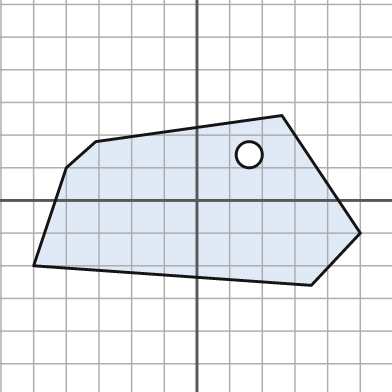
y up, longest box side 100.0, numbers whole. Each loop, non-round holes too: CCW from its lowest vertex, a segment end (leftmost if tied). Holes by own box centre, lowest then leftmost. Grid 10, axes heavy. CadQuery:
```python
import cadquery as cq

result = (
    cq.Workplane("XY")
    .moveTo(35.0, -26.0)
    .lineTo(50.0, -10.0)
    .lineTo(26.0, 26.0)
    .lineTo(-31.0, 18.0)
    .lineTo(-40.0, 10.0)
    .lineTo(-50.0, -20.0)
    .close()
    .moveTo(16.0, 14.0)
    .circle(4.0)
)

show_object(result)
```